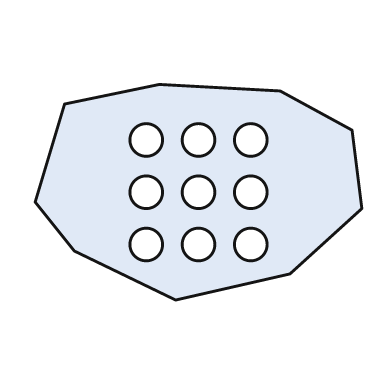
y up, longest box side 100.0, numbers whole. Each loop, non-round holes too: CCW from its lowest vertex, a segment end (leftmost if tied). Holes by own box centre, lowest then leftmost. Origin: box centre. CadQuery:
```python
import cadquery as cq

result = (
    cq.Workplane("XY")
    .moveTo(-7.0, -33.0)
    .lineTo(28.0, -25.0)
    .lineTo(50.0, -5.0)
    .lineTo(47.0, 19.0)
    .lineTo(25.0, 31.0)
    .lineTo(-12.0, 33.0)
    .lineTo(-41.0, 27.0)
    .lineTo(-50.0, -3.0)
    .lineTo(-38.0, -18.0)
    .close()
    .moveTo(-16.0, -16.0)
    .circle(5.0)
    .moveTo(0.0, -16.0)
    .circle(5.0)
    .moveTo(16.0, -16.0)
    .circle(5.0)
    .moveTo(-16.0, 0.0)
    .circle(5.0)
    .moveTo(0.0, 0.0)
    .circle(5.0)
    .moveTo(16.0, 0.0)
    .circle(5.0)
    .moveTo(-16.0, 16.0)
    .circle(5.0)
    .moveTo(0.0, 16.0)
    .circle(5.0)
    .moveTo(16.0, 16.0)
    .circle(5.0)
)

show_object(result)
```